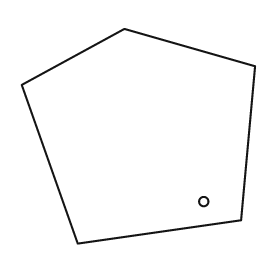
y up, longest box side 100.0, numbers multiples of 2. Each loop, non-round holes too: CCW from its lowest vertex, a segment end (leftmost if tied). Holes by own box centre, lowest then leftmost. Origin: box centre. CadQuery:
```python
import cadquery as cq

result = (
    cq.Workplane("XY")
    .moveTo(-26.0, -46.0)
    .lineTo(44.0, -36.0)
    .lineTo(50.0, 30.0)
    .lineTo(-6.0, 46.0)
    .lineTo(-50.0, 22.0)
    .close()
    .moveTo(28.0, -28.0)
    .circle(2.0)
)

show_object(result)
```